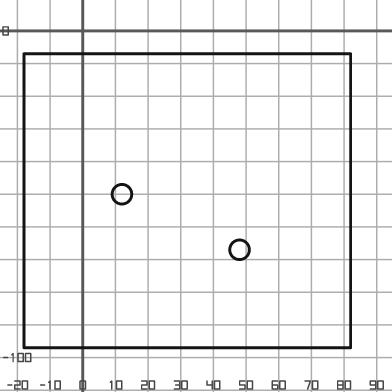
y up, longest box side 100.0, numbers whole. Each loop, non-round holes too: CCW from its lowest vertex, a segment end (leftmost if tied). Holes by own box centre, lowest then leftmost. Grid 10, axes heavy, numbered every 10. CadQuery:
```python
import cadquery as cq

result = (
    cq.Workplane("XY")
    .moveTo(-18.0, -97.0)
    .lineTo(82.0, -97.0)
    .lineTo(82.0, -7.0)
    .lineTo(-18.0, -7.0)
    .close()
    .moveTo(48.0, -67.0)
    .circle(3.0)
    .moveTo(12.0, -50.0)
    .circle(3.0)
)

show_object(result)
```